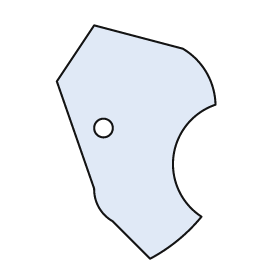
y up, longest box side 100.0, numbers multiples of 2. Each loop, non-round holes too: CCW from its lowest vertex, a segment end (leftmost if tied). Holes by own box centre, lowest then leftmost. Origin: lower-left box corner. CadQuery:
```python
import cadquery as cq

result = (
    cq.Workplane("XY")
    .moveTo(40.0, 0.0)
    .threePointArc((52.0, 8.0), (62.0, 18.0))
    .threePointArc((50.0, 44.0), (68.0, 66.0))
    .threePointArc((64.0, 80.0), (54.0, 90.0))
    .lineTo(16.0, 100.0)
    .lineTo(0.0, 76.0)
    .lineTo(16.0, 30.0)
    .threePointArc((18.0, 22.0), (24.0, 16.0))
    .close()
    .moveTo(20.0, 56.0)
    .circle(4.0)
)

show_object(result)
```